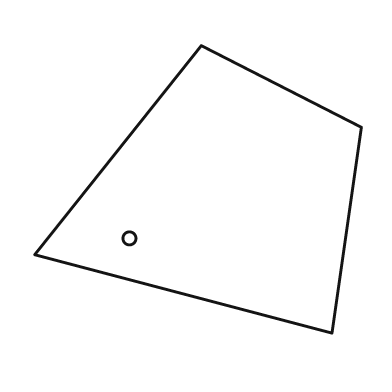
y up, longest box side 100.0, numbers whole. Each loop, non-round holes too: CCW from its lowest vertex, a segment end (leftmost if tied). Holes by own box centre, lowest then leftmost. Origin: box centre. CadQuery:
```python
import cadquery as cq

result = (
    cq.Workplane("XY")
    .moveTo(41.0, -44.0)
    .lineTo(50.0, 19.0)
    .lineTo(1.0, 44.0)
    .lineTo(-50.0, -20.0)
    .close()
    .moveTo(-21.0, -15.0)
    .circle(2.0)
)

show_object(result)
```